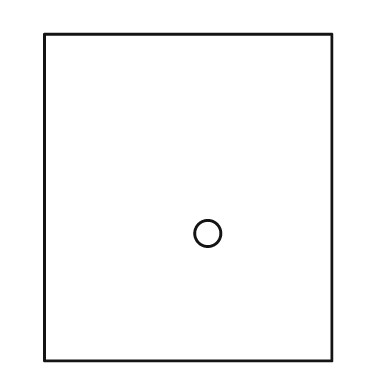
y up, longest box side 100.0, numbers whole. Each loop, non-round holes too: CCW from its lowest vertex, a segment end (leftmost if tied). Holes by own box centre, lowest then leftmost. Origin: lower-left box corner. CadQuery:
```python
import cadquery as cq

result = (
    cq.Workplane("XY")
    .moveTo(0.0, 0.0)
    .lineTo(88.0, 0.0)
    .lineTo(88.0, 100.0)
    .lineTo(0.0, 100.0)
    .close()
    .moveTo(50.0, 39.0)
    .circle(4.0)
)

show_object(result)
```